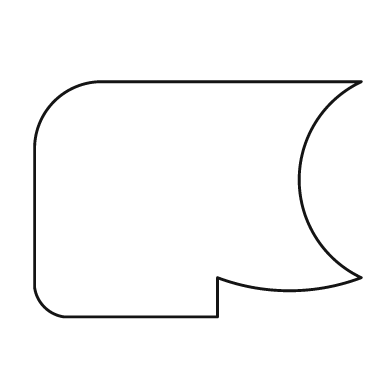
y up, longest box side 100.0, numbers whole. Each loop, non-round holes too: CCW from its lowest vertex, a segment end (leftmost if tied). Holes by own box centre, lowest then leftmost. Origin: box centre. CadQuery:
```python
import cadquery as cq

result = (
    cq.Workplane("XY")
    .moveTo(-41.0, -36.0)
    .lineTo(6.0, -36.0)
    .lineTo(6.0, -24.0)
    .threePointArc((28.0, -28.0), (50.0, -24.0))
    .threePointArc((31.0, 6.0), (50.0, 36.0))
    .lineTo(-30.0, 36.0)
    .threePointArc((-44.0, 30.0), (-50.0, 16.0))
    .lineTo(-50.0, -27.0)
    .threePointArc((-47.0, -33.0), (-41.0, -36.0))
    .close()
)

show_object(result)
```